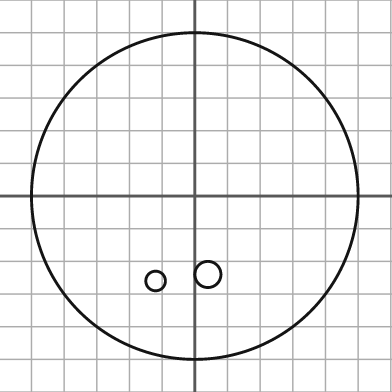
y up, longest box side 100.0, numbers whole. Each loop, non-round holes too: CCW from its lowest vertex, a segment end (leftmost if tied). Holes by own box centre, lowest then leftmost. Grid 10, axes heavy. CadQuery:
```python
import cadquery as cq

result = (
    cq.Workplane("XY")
    .moveTo(0.0, 0.0)
    .circle(50.0)
    .moveTo(-12.0, -26.0)
    .circle(3.0)
    .moveTo(4.0, -24.0)
    .circle(4.0)
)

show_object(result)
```